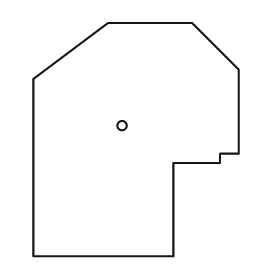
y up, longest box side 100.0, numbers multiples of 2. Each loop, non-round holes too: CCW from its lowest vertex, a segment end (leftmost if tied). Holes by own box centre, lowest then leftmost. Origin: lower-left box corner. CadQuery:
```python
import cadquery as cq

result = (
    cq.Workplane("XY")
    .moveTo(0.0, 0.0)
    .lineTo(60.0, 0.0)
    .lineTo(60.0, 40.0)
    .lineTo(80.0, 40.0)
    .lineTo(80.0, 44.0)
    .lineTo(88.0, 44.0)
    .lineTo(88.0, 80.0)
    .lineTo(68.0, 100.0)
    .lineTo(32.0, 100.0)
    .lineTo(0.0, 76.0)
    .close()
    .moveTo(38.0, 56.0)
    .circle(2.0)
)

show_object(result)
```